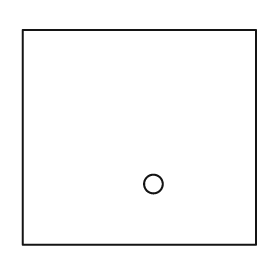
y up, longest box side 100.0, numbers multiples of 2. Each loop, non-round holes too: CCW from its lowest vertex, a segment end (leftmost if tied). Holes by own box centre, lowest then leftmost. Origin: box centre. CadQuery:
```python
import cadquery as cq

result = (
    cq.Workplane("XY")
    .moveTo(-50.0, -46.0)
    .lineTo(50.0, -46.0)
    .lineTo(50.0, 46.0)
    .lineTo(-50.0, 46.0)
    .close()
    .moveTo(6.0, -20.0)
    .circle(4.0)
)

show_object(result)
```